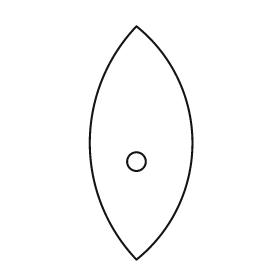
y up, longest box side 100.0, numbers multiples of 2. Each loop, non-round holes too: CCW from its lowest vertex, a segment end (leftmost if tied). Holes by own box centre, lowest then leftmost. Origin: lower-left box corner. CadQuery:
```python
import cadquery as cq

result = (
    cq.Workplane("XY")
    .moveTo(20.0, 0.0)
    .threePointArc((44.0, 50.0), (20.0, 100.0))
    .threePointArc((0.0, 50.0), (20.0, 0.0))
    .close()
    .moveTo(20.0, 42.0)
    .circle(4.0)
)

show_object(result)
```